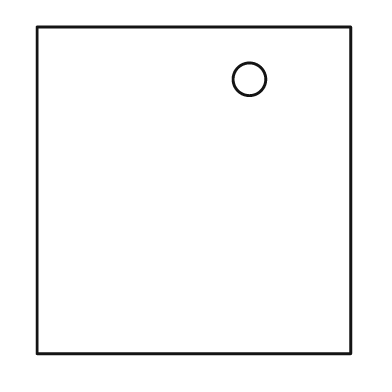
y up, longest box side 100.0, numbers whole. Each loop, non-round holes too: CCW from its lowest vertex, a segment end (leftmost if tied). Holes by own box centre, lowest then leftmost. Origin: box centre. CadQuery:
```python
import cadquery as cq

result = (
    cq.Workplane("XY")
    .moveTo(-48.0, -50.0)
    .lineTo(48.0, -50.0)
    .lineTo(48.0, 50.0)
    .lineTo(-48.0, 50.0)
    .close()
    .moveTo(17.0, 34.0)
    .circle(5.0)
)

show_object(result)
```